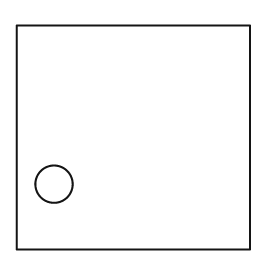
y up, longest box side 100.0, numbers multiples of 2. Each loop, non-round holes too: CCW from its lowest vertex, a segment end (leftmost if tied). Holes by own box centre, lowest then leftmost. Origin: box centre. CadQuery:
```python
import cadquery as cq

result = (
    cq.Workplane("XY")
    .moveTo(-50.0, -48.0)
    .lineTo(50.0, -48.0)
    .lineTo(50.0, 48.0)
    .lineTo(-50.0, 48.0)
    .close()
    .moveTo(-34.0, -20.0)
    .circle(8.0)
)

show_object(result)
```